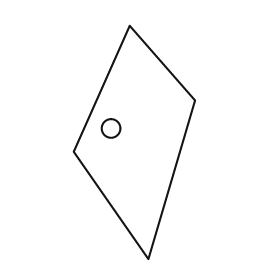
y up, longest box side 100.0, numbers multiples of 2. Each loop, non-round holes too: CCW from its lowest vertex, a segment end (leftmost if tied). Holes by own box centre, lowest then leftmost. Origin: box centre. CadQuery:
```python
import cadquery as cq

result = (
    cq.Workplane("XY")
    .moveTo(6.0, -50.0)
    .lineTo(26.0, 18.0)
    .lineTo(-2.0, 50.0)
    .lineTo(-26.0, -4.0)
    .close()
    .moveTo(-10.0, 6.0)
    .circle(4.0)
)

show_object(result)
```